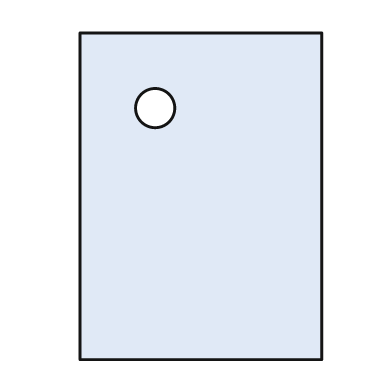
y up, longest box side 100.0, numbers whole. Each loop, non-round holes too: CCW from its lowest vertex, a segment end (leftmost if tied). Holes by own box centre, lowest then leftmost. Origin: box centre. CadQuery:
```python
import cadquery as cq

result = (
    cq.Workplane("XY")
    .moveTo(-37.0, -50.0)
    .lineTo(37.0, -50.0)
    .lineTo(37.0, 50.0)
    .lineTo(-37.0, 50.0)
    .close()
    .moveTo(-14.0, 27.0)
    .circle(6.0)
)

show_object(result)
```